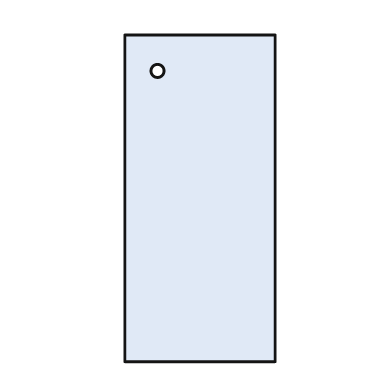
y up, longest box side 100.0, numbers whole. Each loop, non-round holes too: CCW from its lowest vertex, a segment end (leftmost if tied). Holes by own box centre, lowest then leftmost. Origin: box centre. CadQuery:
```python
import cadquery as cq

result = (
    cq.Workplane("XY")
    .moveTo(-23.0, -50.0)
    .lineTo(23.0, -50.0)
    .lineTo(23.0, 50.0)
    .lineTo(-23.0, 50.0)
    .close()
    .moveTo(-13.0, 39.0)
    .circle(2.0)
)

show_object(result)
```